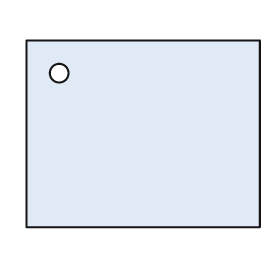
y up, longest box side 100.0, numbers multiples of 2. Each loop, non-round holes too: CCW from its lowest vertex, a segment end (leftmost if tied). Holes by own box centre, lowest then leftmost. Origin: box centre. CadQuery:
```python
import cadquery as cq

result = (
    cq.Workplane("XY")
    .moveTo(-50.0, -40.0)
    .lineTo(50.0, -40.0)
    .lineTo(50.0, 40.0)
    .lineTo(-50.0, 40.0)
    .close()
    .moveTo(-36.0, 26.0)
    .circle(4.0)
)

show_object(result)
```